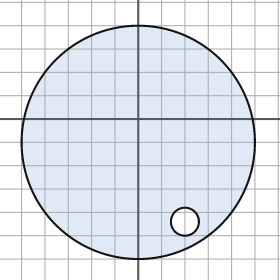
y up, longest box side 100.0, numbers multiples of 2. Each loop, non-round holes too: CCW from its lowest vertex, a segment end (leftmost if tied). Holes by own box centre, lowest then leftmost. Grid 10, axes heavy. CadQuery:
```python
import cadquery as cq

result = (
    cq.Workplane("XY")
    .moveTo(0.0, -10.0)
    .circle(50.0)
    .moveTo(20.0, -44.0)
    .circle(6.0)
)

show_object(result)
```